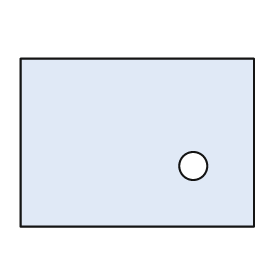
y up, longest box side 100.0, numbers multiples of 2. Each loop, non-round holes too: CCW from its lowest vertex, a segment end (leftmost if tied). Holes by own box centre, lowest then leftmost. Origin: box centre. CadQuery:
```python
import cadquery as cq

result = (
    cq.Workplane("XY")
    .moveTo(-50.0, -36.0)
    .lineTo(50.0, -36.0)
    .lineTo(50.0, 36.0)
    .lineTo(-50.0, 36.0)
    .close()
    .moveTo(24.0, -10.0)
    .circle(6.0)
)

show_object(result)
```